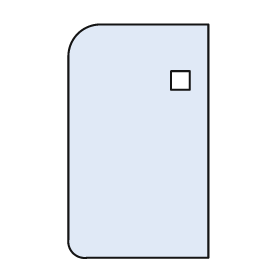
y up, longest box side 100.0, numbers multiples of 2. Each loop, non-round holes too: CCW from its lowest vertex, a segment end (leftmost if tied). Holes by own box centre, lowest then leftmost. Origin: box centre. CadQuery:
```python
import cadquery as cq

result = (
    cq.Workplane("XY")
    .moveTo(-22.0, -50.0)
    .lineTo(30.0, -50.0)
    .lineTo(30.0, 50.0)
    .lineTo(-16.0, 50.0)
    .threePointArc((-26.0, 46.0), (-30.0, 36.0))
    .lineTo(-30.0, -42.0)
    .threePointArc((-28.0, -48.0), (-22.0, -50.0))
    .close()
    .moveTo(14.0, 22.0)
    .lineTo(22.0, 22.0)
    .lineTo(22.0, 30.0)
    .lineTo(14.0, 30.0)
    .close()
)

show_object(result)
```